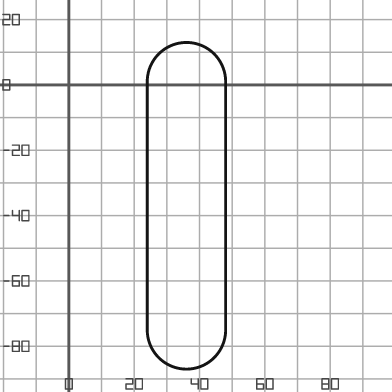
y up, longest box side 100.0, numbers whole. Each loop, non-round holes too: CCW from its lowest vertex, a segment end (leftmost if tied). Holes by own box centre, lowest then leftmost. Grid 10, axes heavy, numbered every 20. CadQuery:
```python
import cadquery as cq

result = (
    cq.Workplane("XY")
    .moveTo(24.0, -75.0)
    .threePointArc((36.0, -87.0), (48.0, -75.0))
    .lineTo(48.0, 1.0)
    .threePointArc((36.0, 13.0), (24.0, 1.0))
    .close()
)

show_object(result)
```